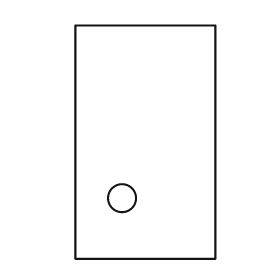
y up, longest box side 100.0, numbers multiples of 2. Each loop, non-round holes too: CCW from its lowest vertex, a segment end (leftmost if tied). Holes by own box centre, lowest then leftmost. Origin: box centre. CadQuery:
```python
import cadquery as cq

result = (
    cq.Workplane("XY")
    .moveTo(-30.0, -50.0)
    .lineTo(30.0, -50.0)
    .lineTo(30.0, 50.0)
    .lineTo(-30.0, 50.0)
    .close()
    .moveTo(-10.0, -24.0)
    .circle(6.0)
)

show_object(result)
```